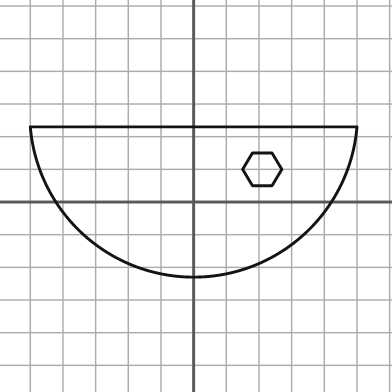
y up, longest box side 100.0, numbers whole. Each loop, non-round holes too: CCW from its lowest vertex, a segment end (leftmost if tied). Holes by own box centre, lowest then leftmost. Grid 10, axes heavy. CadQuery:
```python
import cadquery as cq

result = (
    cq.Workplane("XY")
    .moveTo(-50.0, 23.0)
    .threePointArc((0.0, -23.0), (50.0, 23.0))
    .close()
    .moveTo(18.0, 5.0)
    .lineTo(24.0, 5.0)
    .lineTo(27.0, 10.0)
    .lineTo(24.0, 15.0)
    .lineTo(18.0, 15.0)
    .lineTo(15.0, 10.0)
    .close()
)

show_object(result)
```